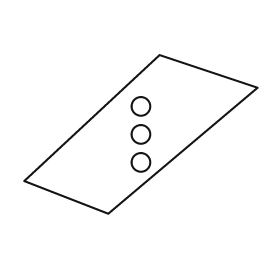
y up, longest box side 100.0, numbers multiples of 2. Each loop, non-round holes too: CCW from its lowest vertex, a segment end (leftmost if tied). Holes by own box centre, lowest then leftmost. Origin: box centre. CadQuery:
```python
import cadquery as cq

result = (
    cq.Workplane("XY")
    .moveTo(-14.0, -34.0)
    .lineTo(50.0, 20.0)
    .lineTo(8.0, 34.0)
    .lineTo(-50.0, -20.0)
    .close()
    .moveTo(0.0, -12.0)
    .circle(4.0)
    .moveTo(0.0, 0.0)
    .circle(4.0)
    .moveTo(0.0, 12.0)
    .circle(4.0)
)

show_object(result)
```